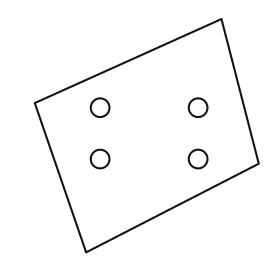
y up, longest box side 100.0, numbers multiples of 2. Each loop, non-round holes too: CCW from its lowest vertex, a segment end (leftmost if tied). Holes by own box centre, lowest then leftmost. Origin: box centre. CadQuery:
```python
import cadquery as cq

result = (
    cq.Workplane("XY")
    .moveTo(-26.0, -50.0)
    .lineTo(48.0, -12.0)
    .lineTo(32.0, 50.0)
    .lineTo(-48.0, 14.0)
    .close()
    .moveTo(-20.0, -10.0)
    .circle(4.0)
    .moveTo(22.0, -10.0)
    .circle(4.0)
    .moveTo(-20.0, 12.0)
    .circle(4.0)
    .moveTo(22.0, 12.0)
    .circle(4.0)
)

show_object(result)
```